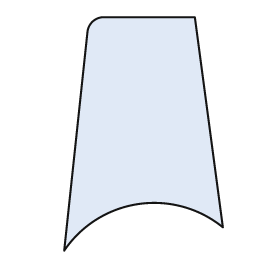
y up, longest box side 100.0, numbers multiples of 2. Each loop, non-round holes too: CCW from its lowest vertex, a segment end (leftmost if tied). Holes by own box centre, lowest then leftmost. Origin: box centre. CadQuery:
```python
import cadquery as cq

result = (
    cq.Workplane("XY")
    .moveTo(-34.0, -50.0)
    .threePointArc((-2.0, -30.0), (34.0, -40.0))
    .lineTo(22.0, 50.0)
    .lineTo(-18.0, 50.0)
    .threePointArc((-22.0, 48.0), (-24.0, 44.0))
    .close()
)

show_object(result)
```